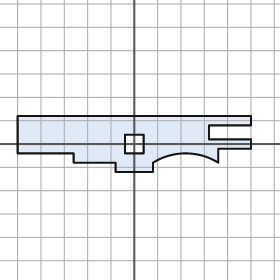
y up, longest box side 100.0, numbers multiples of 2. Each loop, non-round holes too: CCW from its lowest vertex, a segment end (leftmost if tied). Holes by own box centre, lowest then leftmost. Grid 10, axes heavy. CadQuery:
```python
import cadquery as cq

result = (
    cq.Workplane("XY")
    .moveTo(-8.0, -12.0)
    .lineTo(8.0, -12.0)
    .lineTo(8.0, -8.0)
    .threePointArc((22.0, -4.0), (36.0, -8.0))
    .lineTo(36.0, -2.0)
    .lineTo(50.0, -2.0)
    .lineTo(50.0, 2.0)
    .lineTo(32.0, 2.0)
    .lineTo(32.0, 8.0)
    .lineTo(50.0, 8.0)
    .lineTo(50.0, 12.0)
    .lineTo(-50.0, 12.0)
    .lineTo(-50.0, -4.0)
    .lineTo(-26.0, -4.0)
    .lineTo(-26.0, -8.0)
    .lineTo(-8.0, -8.0)
    .close()
    .moveTo(-4.0, -4.0)
    .lineTo(4.0, -4.0)
    .lineTo(4.0, 4.0)
    .lineTo(-4.0, 4.0)
    .close()
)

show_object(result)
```